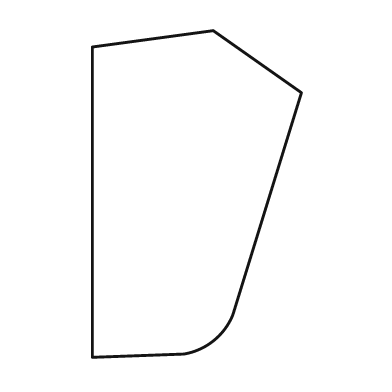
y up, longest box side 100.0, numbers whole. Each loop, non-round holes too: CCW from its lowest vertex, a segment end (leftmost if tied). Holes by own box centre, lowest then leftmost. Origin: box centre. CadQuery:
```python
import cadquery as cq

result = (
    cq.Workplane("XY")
    .moveTo(-32.0, -50.0)
    .lineTo(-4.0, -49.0)
    .threePointArc((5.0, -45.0), (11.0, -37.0))
    .lineTo(32.0, 31.0)
    .lineTo(5.0, 50.0)
    .lineTo(-32.0, 45.0)
    .close()
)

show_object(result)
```